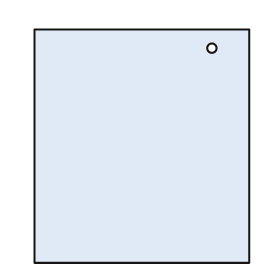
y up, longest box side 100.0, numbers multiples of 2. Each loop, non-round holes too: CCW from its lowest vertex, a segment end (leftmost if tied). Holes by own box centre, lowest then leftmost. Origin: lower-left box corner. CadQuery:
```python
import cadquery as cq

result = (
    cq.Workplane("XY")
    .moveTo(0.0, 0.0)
    .lineTo(92.0, 0.0)
    .lineTo(92.0, 100.0)
    .lineTo(0.0, 100.0)
    .close()
    .moveTo(76.0, 92.0)
    .circle(2.0)
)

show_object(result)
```